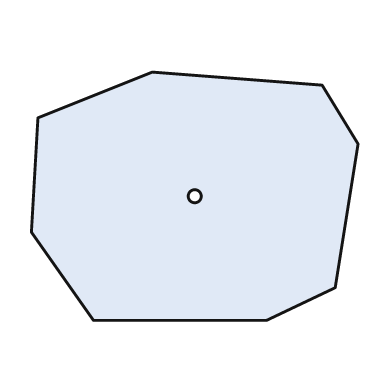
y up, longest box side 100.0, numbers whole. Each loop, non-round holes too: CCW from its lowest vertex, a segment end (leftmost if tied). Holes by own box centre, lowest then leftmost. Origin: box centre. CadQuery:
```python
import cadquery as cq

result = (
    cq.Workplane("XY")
    .moveTo(-31.0, -38.0)
    .lineTo(22.0, -38.0)
    .lineTo(43.0, -28.0)
    .lineTo(50.0, 16.0)
    .lineTo(39.0, 34.0)
    .lineTo(-13.0, 38.0)
    .lineTo(-48.0, 24.0)
    .lineTo(-50.0, -11.0)
    .close()
    .moveTo(0.0, 0.0)
    .circle(2.0)
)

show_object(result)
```